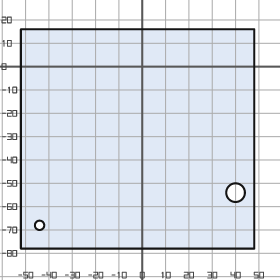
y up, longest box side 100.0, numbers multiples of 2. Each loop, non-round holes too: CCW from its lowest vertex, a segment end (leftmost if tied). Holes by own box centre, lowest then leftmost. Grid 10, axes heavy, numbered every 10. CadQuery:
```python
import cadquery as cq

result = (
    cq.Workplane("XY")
    .moveTo(-52.0, -78.0)
    .lineTo(48.0, -78.0)
    .lineTo(48.0, 16.0)
    .lineTo(-52.0, 16.0)
    .close()
    .moveTo(-44.0, -68.0)
    .circle(2.0)
    .moveTo(40.0, -54.0)
    .circle(4.0)
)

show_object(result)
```